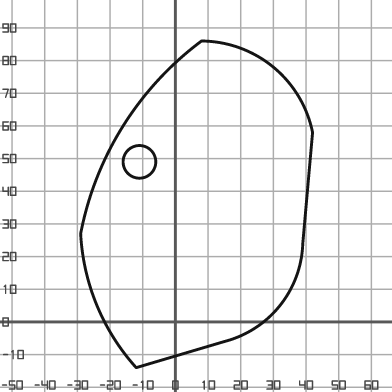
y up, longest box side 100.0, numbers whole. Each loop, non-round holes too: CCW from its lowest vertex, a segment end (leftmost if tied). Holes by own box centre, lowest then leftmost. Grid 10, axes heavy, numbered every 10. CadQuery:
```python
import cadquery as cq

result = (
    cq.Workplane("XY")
    .moveTo(-12.0, -14.0)
    .lineTo(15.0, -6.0)
    .threePointArc((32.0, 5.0), (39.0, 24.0))
    .lineTo(42.0, 58.0)
    .threePointArc((30.0, 78.0), (8.0, 86.0))
    .threePointArc((-16.0, 60.0), (-29.0, 27.0))
    .threePointArc((-24.0, 5.0), (-12.0, -14.0))
    .close()
    .moveTo(-11.0, 49.0)
    .circle(5.0)
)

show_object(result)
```